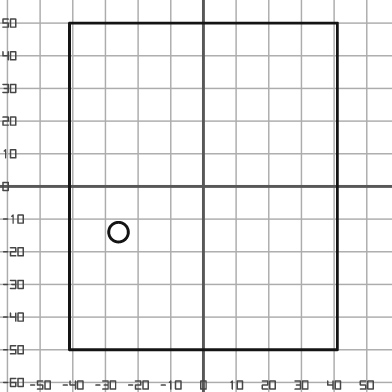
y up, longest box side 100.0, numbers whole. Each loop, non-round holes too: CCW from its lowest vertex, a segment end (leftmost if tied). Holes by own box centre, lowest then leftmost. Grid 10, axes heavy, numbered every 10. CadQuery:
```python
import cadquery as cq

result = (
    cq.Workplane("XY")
    .moveTo(-41.0, -50.0)
    .lineTo(41.0, -50.0)
    .lineTo(41.0, 50.0)
    .lineTo(-41.0, 50.0)
    .close()
    .moveTo(-26.0, -14.0)
    .circle(3.0)
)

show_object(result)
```